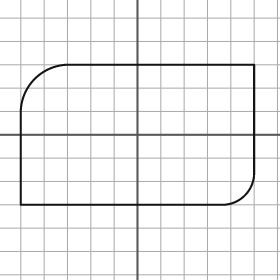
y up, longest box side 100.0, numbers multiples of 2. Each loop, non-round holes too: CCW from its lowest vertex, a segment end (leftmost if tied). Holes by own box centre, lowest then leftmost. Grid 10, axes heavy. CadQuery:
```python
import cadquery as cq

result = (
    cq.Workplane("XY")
    .moveTo(-50.0, -30.0)
    .lineTo(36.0, -30.0)
    .threePointArc((46.0, -26.0), (50.0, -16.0))
    .lineTo(50.0, 30.0)
    .lineTo(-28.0, 30.0)
    .threePointArc((-44.0, 24.0), (-50.0, 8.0))
    .close()
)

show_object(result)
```